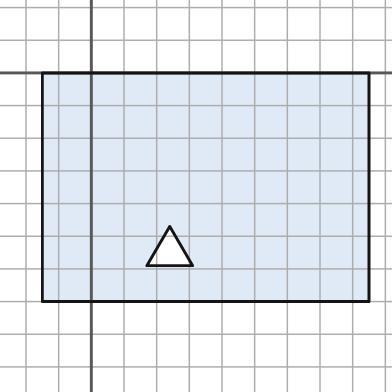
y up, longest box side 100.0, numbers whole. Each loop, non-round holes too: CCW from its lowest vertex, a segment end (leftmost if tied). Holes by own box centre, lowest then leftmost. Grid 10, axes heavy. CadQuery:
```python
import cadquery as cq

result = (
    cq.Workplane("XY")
    .moveTo(-15.0, -70.0)
    .lineTo(85.0, -70.0)
    .lineTo(85.0, 0.0)
    .lineTo(-15.0, 0.0)
    .close()
    .moveTo(17.0, -59.0)
    .lineTo(31.0, -59.0)
    .lineTo(24.0, -47.0)
    .close()
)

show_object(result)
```